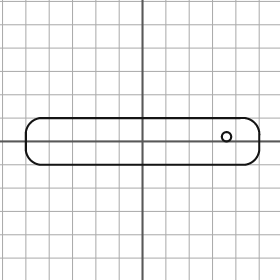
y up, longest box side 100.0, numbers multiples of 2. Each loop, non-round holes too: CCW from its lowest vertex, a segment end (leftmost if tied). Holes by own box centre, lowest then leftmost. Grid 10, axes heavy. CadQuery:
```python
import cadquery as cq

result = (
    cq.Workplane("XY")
    .moveTo(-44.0, -10.0)
    .lineTo(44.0, -10.0)
    .threePointArc((48.0, -8.0), (50.0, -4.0))
    .lineTo(50.0, 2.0)
    .threePointArc((48.0, 8.0), (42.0, 10.0))
    .lineTo(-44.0, 10.0)
    .threePointArc((-48.0, 8.0), (-50.0, 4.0))
    .lineTo(-50.0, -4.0)
    .threePointArc((-48.0, -8.0), (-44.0, -10.0))
    .close()
    .moveTo(36.0, 2.0)
    .circle(2.0)
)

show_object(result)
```